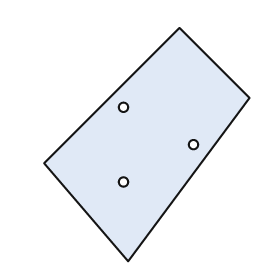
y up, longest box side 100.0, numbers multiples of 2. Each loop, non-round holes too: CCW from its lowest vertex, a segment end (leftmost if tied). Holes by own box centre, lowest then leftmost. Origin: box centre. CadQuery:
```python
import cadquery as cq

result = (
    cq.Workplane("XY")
    .moveTo(-8.0, -50.0)
    .lineTo(44.0, 20.0)
    .lineTo(14.0, 50.0)
    .lineTo(-44.0, -8.0)
    .close()
    .moveTo(-10.0, -16.0)
    .circle(2.0)
    .moveTo(20.0, 0.0)
    .circle(2.0)
    .moveTo(-10.0, 16.0)
    .circle(2.0)
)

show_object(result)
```